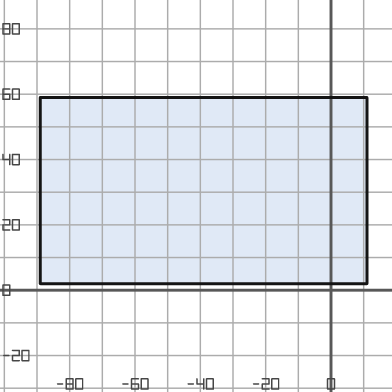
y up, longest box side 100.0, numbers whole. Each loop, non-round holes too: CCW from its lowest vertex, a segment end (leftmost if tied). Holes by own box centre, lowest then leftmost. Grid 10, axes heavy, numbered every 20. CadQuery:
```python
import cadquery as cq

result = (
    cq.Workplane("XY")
    .moveTo(-89.0, 2.0)
    .lineTo(11.0, 2.0)
    .lineTo(11.0, 59.0)
    .lineTo(-89.0, 59.0)
    .close()
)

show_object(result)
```